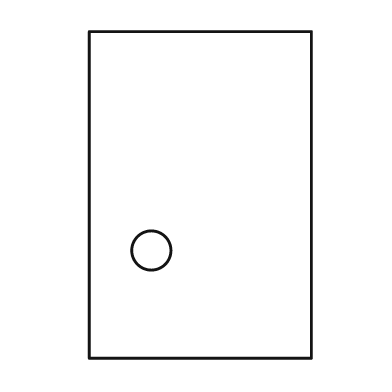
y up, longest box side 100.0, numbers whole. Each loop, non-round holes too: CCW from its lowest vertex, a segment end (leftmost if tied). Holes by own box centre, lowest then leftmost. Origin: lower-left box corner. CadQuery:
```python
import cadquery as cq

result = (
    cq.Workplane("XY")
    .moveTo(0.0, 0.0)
    .lineTo(68.0, 0.0)
    .lineTo(68.0, 100.0)
    .lineTo(0.0, 100.0)
    .close()
    .moveTo(19.0, 33.0)
    .circle(6.0)
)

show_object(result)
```